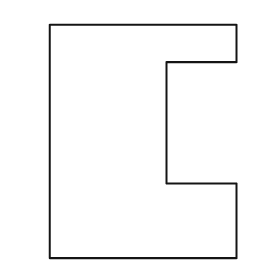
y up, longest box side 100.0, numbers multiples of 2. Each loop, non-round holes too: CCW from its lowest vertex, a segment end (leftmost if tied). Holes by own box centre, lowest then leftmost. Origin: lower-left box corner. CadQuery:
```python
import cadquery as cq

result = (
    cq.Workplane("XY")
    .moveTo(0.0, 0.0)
    .lineTo(80.0, 0.0)
    .lineTo(80.0, 32.0)
    .lineTo(50.0, 32.0)
    .lineTo(50.0, 84.0)
    .lineTo(80.0, 84.0)
    .lineTo(80.0, 100.0)
    .lineTo(0.0, 100.0)
    .close()
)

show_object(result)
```